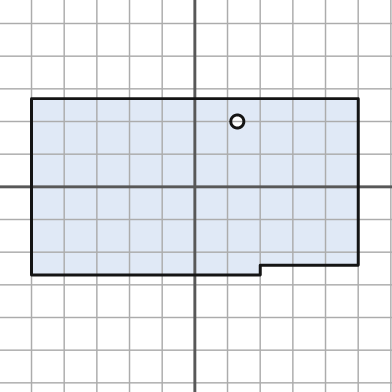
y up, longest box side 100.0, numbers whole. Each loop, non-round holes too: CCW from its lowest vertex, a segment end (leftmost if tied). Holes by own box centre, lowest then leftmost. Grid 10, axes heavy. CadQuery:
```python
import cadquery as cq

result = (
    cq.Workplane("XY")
    .moveTo(-50.0, -27.0)
    .lineTo(20.0, -27.0)
    .lineTo(20.0, -24.0)
    .lineTo(50.0, -24.0)
    .lineTo(50.0, 27.0)
    .lineTo(-50.0, 27.0)
    .close()
    .moveTo(13.0, 20.0)
    .circle(2.0)
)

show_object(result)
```